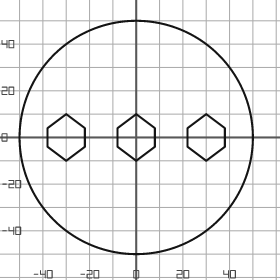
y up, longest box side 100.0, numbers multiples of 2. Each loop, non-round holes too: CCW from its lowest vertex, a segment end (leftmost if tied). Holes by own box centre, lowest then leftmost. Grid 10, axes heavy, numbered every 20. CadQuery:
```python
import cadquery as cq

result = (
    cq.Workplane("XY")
    .moveTo(0.0, 0.0)
    .circle(50.0)
    .moveTo(-30.0, -10.0)
    .lineTo(-22.0, -4.0)
    .lineTo(-22.0, 4.0)
    .lineTo(-30.0, 10.0)
    .lineTo(-38.0, 4.0)
    .lineTo(-38.0, -4.0)
    .close()
    .moveTo(0.0, -10.0)
    .lineTo(8.0, -4.0)
    .lineTo(8.0, 4.0)
    .lineTo(0.0, 10.0)
    .lineTo(-8.0, 4.0)
    .lineTo(-8.0, -4.0)
    .close()
    .moveTo(30.0, -10.0)
    .lineTo(38.0, -4.0)
    .lineTo(38.0, 4.0)
    .lineTo(30.0, 10.0)
    .lineTo(22.0, 4.0)
    .lineTo(22.0, -4.0)
    .close()
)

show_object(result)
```